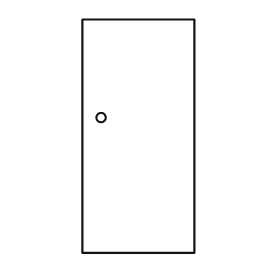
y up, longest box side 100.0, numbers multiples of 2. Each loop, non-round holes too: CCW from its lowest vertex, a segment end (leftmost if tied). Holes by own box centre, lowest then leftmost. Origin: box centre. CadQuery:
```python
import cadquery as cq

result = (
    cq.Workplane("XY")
    .moveTo(-24.0, -50.0)
    .lineTo(24.0, -50.0)
    .lineTo(24.0, 50.0)
    .lineTo(-24.0, 50.0)
    .close()
    .moveTo(-16.0, 8.0)
    .circle(2.0)
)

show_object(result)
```